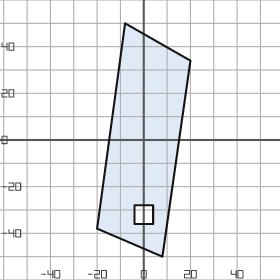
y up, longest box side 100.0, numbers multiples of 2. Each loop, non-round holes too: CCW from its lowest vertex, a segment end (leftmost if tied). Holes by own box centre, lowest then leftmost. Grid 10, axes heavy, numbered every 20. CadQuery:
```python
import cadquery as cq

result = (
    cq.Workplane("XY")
    .moveTo(8.0, -50.0)
    .lineTo(20.0, 34.0)
    .lineTo(-8.0, 50.0)
    .lineTo(-20.0, -38.0)
    .close()
    .moveTo(-4.0, -36.0)
    .lineTo(4.0, -36.0)
    .lineTo(4.0, -28.0)
    .lineTo(-4.0, -28.0)
    .close()
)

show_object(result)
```